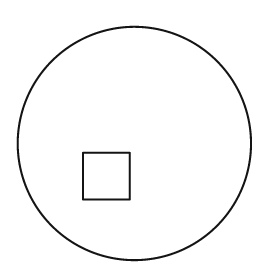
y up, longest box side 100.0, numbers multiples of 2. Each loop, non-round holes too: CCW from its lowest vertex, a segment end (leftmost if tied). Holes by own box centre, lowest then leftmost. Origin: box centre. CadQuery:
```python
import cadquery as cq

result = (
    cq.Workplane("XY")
    .moveTo(0.0, 0.0)
    .circle(50.0)
    .moveTo(-22.0, -24.0)
    .lineTo(-2.0, -24.0)
    .lineTo(-2.0, -4.0)
    .lineTo(-22.0, -4.0)
    .close()
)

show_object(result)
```